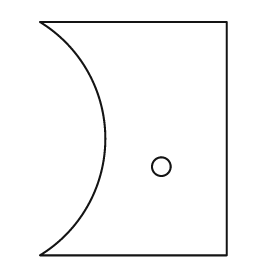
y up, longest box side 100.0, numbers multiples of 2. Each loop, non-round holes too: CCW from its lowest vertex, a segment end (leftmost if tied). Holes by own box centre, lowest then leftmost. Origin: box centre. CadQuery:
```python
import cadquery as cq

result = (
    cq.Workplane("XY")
    .moveTo(-40.0, -50.0)
    .lineTo(40.0, -50.0)
    .lineTo(40.0, 50.0)
    .lineTo(-40.0, 50.0)
    .threePointArc((-12.0, 0.0), (-40.0, -50.0))
    .close()
    .moveTo(12.0, -12.0)
    .circle(4.0)
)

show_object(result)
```